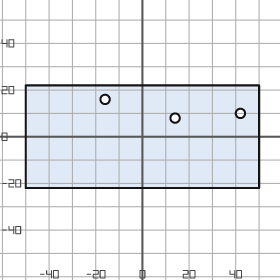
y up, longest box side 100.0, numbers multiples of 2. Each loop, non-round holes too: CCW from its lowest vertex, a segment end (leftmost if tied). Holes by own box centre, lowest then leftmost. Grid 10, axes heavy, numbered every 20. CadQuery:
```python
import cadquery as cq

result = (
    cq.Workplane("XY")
    .moveTo(-50.0, -22.0)
    .lineTo(50.0, -22.0)
    .lineTo(50.0, 22.0)
    .lineTo(-50.0, 22.0)
    .close()
    .moveTo(14.0, 8.0)
    .circle(2.0)
    .moveTo(42.0, 10.0)
    .circle(2.0)
    .moveTo(-16.0, 16.0)
    .circle(2.0)
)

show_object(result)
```